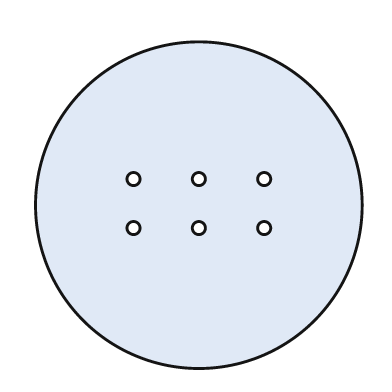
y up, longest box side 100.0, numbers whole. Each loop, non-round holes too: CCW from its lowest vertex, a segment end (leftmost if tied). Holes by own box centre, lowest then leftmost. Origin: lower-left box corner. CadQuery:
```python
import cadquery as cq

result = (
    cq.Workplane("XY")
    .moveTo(50.0, 50.0)
    .circle(50.0)
    .moveTo(30.0, 43.0)
    .circle(2.0)
    .moveTo(50.0, 43.0)
    .circle(2.0)
    .moveTo(70.0, 43.0)
    .circle(2.0)
    .moveTo(30.0, 58.0)
    .circle(2.0)
    .moveTo(50.0, 58.0)
    .circle(2.0)
    .moveTo(70.0, 58.0)
    .circle(2.0)
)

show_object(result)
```